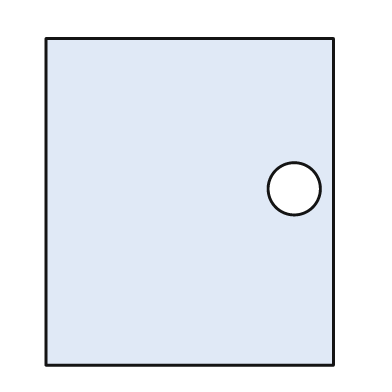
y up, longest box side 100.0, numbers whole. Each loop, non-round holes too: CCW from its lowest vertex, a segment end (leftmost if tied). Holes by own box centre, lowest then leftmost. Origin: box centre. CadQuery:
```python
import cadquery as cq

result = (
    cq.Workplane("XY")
    .moveTo(-44.0, -50.0)
    .lineTo(44.0, -50.0)
    .lineTo(44.0, 50.0)
    .lineTo(-44.0, 50.0)
    .close()
    .moveTo(32.0, 4.0)
    .circle(8.0)
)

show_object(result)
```